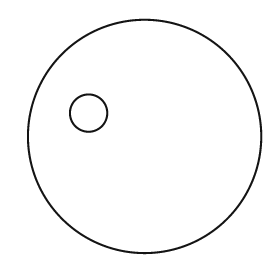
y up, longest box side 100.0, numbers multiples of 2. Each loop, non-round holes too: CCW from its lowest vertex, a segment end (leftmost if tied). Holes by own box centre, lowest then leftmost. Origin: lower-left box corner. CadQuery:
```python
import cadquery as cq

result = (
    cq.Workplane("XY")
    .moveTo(50.0, 50.0)
    .circle(50.0)
    .moveTo(26.0, 60.0)
    .circle(8.0)
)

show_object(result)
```